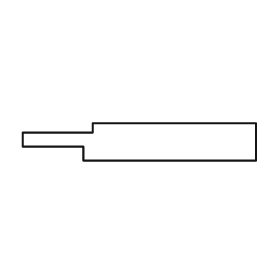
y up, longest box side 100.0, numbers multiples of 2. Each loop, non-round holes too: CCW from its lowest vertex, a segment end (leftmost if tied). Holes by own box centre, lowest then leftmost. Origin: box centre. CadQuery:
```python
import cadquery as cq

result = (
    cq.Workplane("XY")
    .moveTo(-24.0, -8.0)
    .lineTo(50.0, -8.0)
    .lineTo(50.0, 8.0)
    .lineTo(-20.0, 8.0)
    .lineTo(-20.0, 4.0)
    .lineTo(-50.0, 4.0)
    .lineTo(-50.0, -2.0)
    .lineTo(-24.0, -2.0)
    .close()
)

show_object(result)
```